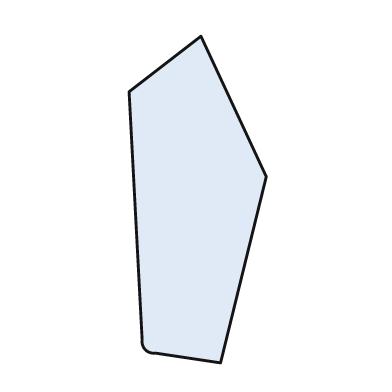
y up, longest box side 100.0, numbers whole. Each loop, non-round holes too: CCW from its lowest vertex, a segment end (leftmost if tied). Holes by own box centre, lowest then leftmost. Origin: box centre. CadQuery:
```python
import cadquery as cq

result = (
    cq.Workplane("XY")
    .moveTo(7.0, -50.0)
    .lineTo(21.0, 7.0)
    .lineTo(1.0, 50.0)
    .lineTo(-21.0, 33.0)
    .lineTo(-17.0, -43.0)
    .threePointArc((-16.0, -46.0), (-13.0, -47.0))
    .close()
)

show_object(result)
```